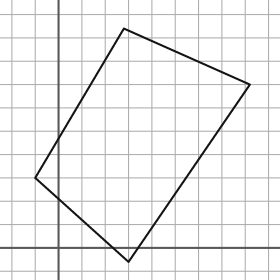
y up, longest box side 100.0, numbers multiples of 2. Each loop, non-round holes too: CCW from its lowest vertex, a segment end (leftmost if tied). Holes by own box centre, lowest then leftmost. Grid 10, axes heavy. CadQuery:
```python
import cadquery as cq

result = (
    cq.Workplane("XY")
    .moveTo(30.0, -6.0)
    .lineTo(82.0, 70.0)
    .lineTo(28.0, 94.0)
    .lineTo(-10.0, 30.0)
    .close()
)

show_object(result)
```